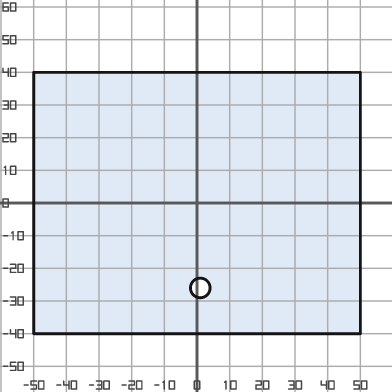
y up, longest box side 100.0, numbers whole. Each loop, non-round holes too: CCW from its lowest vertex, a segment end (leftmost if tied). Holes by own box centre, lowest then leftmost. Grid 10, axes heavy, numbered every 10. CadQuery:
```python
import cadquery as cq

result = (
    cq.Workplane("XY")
    .moveTo(-50.0, -40.0)
    .lineTo(50.0, -40.0)
    .lineTo(50.0, 40.0)
    .lineTo(-50.0, 40.0)
    .close()
    .moveTo(1.0, -26.0)
    .circle(3.0)
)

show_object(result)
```